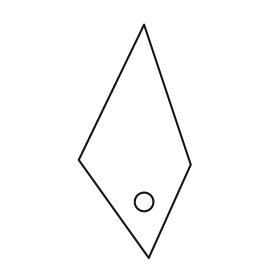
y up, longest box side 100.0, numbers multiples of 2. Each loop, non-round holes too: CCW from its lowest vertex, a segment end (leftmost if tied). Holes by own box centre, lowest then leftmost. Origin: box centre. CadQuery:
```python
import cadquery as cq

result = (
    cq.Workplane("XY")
    .moveTo(6.0, -50.0)
    .lineTo(24.0, -10.0)
    .lineTo(4.0, 50.0)
    .lineTo(-24.0, -8.0)
    .close()
    .moveTo(4.0, -26.0)
    .circle(4.0)
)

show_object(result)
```